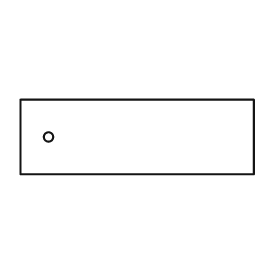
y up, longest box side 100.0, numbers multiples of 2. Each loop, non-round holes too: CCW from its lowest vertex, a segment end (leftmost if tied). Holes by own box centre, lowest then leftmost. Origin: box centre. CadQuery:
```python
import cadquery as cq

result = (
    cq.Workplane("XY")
    .moveTo(-50.0, -16.0)
    .lineTo(50.0, -16.0)
    .lineTo(50.0, 16.0)
    .lineTo(-50.0, 16.0)
    .close()
    .moveTo(-38.0, 0.0)
    .circle(2.0)
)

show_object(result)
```